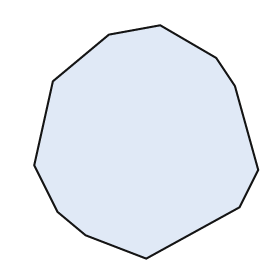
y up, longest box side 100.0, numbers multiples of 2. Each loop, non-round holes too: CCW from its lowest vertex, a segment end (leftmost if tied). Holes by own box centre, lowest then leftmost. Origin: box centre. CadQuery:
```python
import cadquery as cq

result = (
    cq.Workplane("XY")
    .moveTo(0.0, -50.0)
    .lineTo(40.0, -28.0)
    .lineTo(48.0, -12.0)
    .lineTo(38.0, 24.0)
    .lineTo(30.0, 36.0)
    .lineTo(6.0, 50.0)
    .lineTo(-16.0, 46.0)
    .lineTo(-40.0, 26.0)
    .lineTo(-48.0, -10.0)
    .lineTo(-38.0, -30.0)
    .lineTo(-26.0, -40.0)
    .close()
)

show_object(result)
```